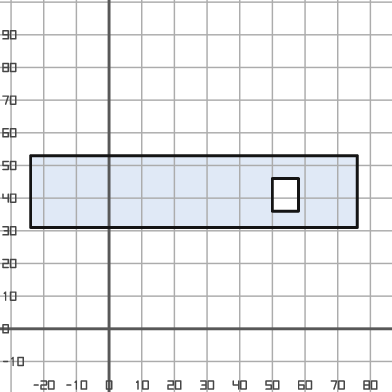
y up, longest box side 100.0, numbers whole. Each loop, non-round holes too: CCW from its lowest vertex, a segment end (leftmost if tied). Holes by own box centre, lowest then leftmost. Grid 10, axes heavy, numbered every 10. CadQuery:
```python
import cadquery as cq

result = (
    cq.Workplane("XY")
    .moveTo(-24.0, 31.0)
    .lineTo(76.0, 31.0)
    .lineTo(76.0, 53.0)
    .lineTo(-24.0, 53.0)
    .close()
    .moveTo(50.0, 36.0)
    .lineTo(58.0, 36.0)
    .lineTo(58.0, 46.0)
    .lineTo(50.0, 46.0)
    .close()
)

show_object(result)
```